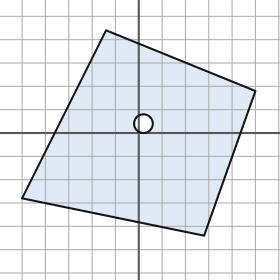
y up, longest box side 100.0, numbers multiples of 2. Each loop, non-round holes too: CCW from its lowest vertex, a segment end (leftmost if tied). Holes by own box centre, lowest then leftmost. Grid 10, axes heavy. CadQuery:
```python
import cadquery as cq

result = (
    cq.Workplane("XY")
    .moveTo(28.0, -44.0)
    .lineTo(50.0, 18.0)
    .lineTo(-14.0, 44.0)
    .lineTo(-50.0, -28.0)
    .close()
    .moveTo(2.0, 4.0)
    .circle(4.0)
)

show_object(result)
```